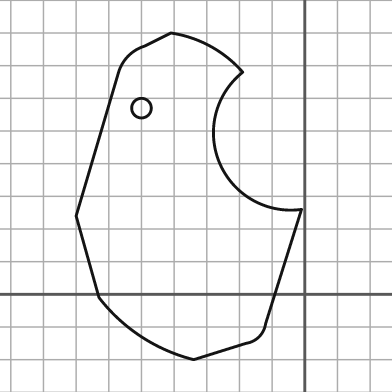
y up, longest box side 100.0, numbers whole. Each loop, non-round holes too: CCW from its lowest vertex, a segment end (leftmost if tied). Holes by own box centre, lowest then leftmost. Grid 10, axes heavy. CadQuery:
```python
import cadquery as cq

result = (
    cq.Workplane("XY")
    .moveTo(-34.0, -20.0)
    .lineTo(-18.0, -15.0)
    .threePointArc((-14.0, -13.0), (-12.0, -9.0))
    .lineTo(-1.0, 26.0)
    .threePointArc((-26.0, 40.0), (-19.0, 68.0))
    .threePointArc((-29.0, 76.0), (-41.0, 80.0))
    .lineTo(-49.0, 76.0)
    .threePointArc((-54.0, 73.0), (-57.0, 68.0))
    .lineTo(-70.0, 24.0)
    .lineTo(-63.0, -1.0)
    .threePointArc((-50.0, -13.0), (-34.0, -20.0))
    .close()
    .moveTo(-50.0, 57.0)
    .circle(3.0)
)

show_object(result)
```